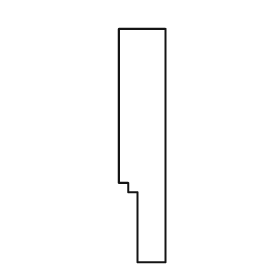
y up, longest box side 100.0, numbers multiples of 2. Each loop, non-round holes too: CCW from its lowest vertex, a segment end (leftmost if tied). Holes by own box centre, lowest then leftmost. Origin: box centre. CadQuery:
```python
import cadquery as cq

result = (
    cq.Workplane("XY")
    .moveTo(-2.0, -50.0)
    .lineTo(10.0, -50.0)
    .lineTo(10.0, 50.0)
    .lineTo(-10.0, 50.0)
    .lineTo(-10.0, -16.0)
    .lineTo(-6.0, -16.0)
    .lineTo(-6.0, -20.0)
    .lineTo(-2.0, -20.0)
    .close()
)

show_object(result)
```